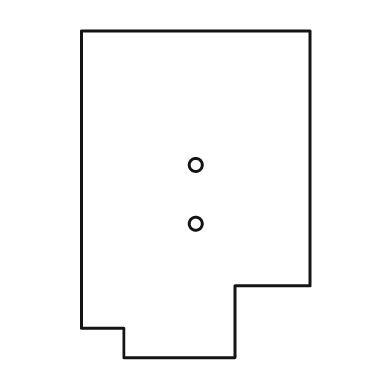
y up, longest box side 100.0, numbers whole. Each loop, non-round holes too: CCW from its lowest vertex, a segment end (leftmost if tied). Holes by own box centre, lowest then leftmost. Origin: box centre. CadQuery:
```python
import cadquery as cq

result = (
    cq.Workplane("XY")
    .moveTo(-22.0, -50.0)
    .lineTo(12.0, -50.0)
    .lineTo(12.0, -28.0)
    .lineTo(35.0, -28.0)
    .lineTo(35.0, 50.0)
    .lineTo(-35.0, 50.0)
    .lineTo(-35.0, -41.0)
    .lineTo(-22.0, -41.0)
    .close()
    .moveTo(0.0, -9.0)
    .circle(2.0)
    .moveTo(0.0, 9.0)
    .circle(2.0)
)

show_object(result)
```